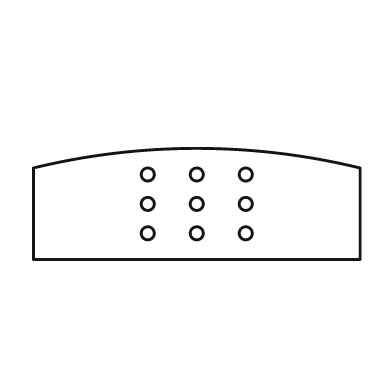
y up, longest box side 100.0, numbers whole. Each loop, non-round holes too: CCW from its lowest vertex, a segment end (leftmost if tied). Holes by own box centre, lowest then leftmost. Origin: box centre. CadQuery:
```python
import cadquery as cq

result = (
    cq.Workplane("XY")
    .moveTo(-50.0, -17.0)
    .lineTo(50.0, -17.0)
    .lineTo(50.0, 11.0)
    .threePointArc((0.0, 17.0), (-50.0, 11.0))
    .close()
    .moveTo(-15.0, -9.0)
    .circle(2.0)
    .moveTo(0.0, -9.0)
    .circle(2.0)
    .moveTo(15.0, -9.0)
    .circle(2.0)
    .moveTo(-15.0, 0.0)
    .circle(2.0)
    .moveTo(0.0, 0.0)
    .circle(2.0)
    .moveTo(15.0, 0.0)
    .circle(2.0)
    .moveTo(-15.0, 9.0)
    .circle(2.0)
    .moveTo(0.0, 9.0)
    .circle(2.0)
    .moveTo(15.0, 9.0)
    .circle(2.0)
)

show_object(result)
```